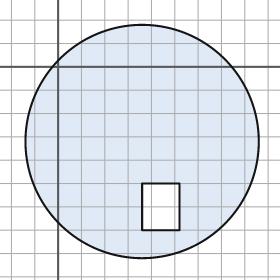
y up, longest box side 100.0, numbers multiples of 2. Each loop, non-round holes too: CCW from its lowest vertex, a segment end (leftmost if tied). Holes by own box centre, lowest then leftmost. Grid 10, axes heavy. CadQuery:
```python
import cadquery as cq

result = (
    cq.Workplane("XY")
    .moveTo(36.0, -32.0)
    .circle(50.0)
    .moveTo(36.0, -70.0)
    .lineTo(52.0, -70.0)
    .lineTo(52.0, -50.0)
    .lineTo(36.0, -50.0)
    .close()
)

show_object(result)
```